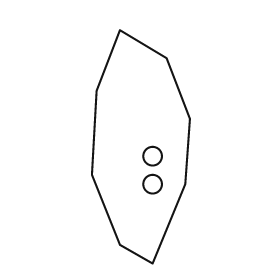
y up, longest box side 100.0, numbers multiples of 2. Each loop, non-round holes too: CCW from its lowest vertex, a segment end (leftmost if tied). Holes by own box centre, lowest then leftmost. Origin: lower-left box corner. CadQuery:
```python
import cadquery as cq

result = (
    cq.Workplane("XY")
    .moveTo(26.0, 0.0)
    .lineTo(40.0, 34.0)
    .lineTo(42.0, 62.0)
    .lineTo(32.0, 88.0)
    .lineTo(12.0, 100.0)
    .lineTo(2.0, 74.0)
    .lineTo(0.0, 38.0)
    .lineTo(12.0, 8.0)
    .close()
    .moveTo(26.0, 34.0)
    .circle(4.0)
    .moveTo(26.0, 46.0)
    .circle(4.0)
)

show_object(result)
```